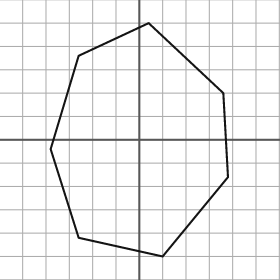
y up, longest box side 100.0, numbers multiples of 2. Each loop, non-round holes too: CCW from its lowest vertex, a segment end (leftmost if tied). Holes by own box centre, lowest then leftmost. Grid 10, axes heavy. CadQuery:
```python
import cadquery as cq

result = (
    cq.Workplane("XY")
    .moveTo(10.0, -50.0)
    .lineTo(38.0, -16.0)
    .lineTo(36.0, 20.0)
    .lineTo(4.0, 50.0)
    .lineTo(-26.0, 36.0)
    .lineTo(-38.0, -4.0)
    .lineTo(-26.0, -42.0)
    .close()
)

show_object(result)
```